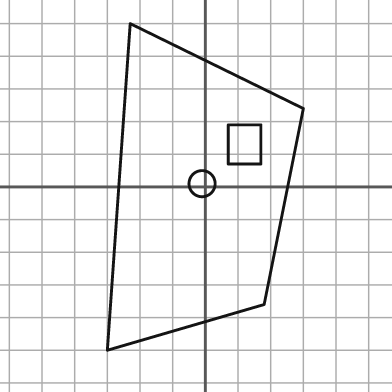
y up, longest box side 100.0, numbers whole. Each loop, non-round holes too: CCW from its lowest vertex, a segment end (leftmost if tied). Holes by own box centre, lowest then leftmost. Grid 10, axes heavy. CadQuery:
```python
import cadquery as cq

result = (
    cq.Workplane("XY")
    .moveTo(-30.0, -50.0)
    .lineTo(18.0, -36.0)
    .lineTo(30.0, 24.0)
    .lineTo(-23.0, 50.0)
    .close()
    .moveTo(-1.0, 1.0)
    .circle(4.0)
    .moveTo(7.0, 7.0)
    .lineTo(17.0, 7.0)
    .lineTo(17.0, 19.0)
    .lineTo(7.0, 19.0)
    .close()
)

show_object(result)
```